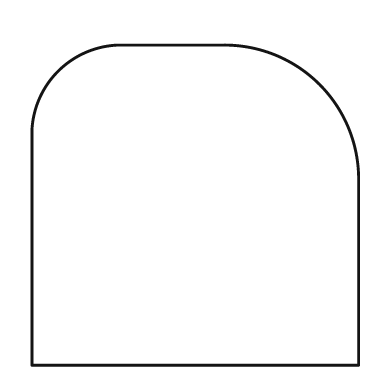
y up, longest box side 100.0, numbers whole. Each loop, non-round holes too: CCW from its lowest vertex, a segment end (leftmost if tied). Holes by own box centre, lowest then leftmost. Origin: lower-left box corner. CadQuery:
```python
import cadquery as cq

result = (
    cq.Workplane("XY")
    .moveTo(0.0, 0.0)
    .lineTo(100.0, 0.0)
    .lineTo(100.0, 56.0)
    .threePointArc((88.0, 86.0), (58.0, 98.0))
    .lineTo(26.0, 98.0)
    .threePointArc((8.0, 90.0), (0.0, 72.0))
    .close()
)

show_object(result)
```